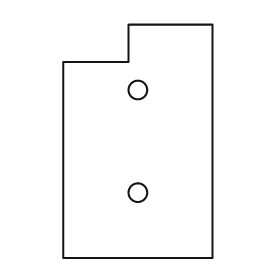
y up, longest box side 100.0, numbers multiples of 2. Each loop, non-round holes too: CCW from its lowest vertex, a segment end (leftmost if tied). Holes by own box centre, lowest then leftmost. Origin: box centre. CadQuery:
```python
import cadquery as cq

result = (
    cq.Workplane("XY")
    .moveTo(-32.0, -50.0)
    .lineTo(32.0, -50.0)
    .lineTo(32.0, 50.0)
    .lineTo(-4.0, 50.0)
    .lineTo(-4.0, 34.0)
    .lineTo(-32.0, 34.0)
    .close()
    .moveTo(0.0, -22.0)
    .circle(4.0)
    .moveTo(0.0, 22.0)
    .circle(4.0)
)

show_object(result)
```